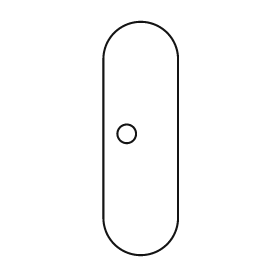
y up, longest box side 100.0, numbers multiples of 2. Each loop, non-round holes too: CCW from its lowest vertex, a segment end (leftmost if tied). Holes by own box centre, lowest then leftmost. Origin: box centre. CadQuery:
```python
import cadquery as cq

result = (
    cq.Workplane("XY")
    .moveTo(-16.0, -34.0)
    .threePointArc((0.0, -50.0), (16.0, -34.0))
    .lineTo(16.0, 34.0)
    .threePointArc((0.0, 50.0), (-16.0, 34.0))
    .close()
    .moveTo(-6.0, 2.0)
    .circle(4.0)
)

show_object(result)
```